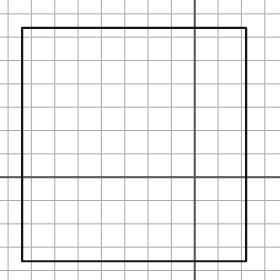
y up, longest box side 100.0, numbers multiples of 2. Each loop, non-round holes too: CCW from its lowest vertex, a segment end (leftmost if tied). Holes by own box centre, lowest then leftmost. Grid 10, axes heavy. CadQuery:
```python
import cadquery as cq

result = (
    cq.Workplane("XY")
    .moveTo(-74.0, -36.0)
    .lineTo(22.0, -36.0)
    .lineTo(22.0, 64.0)
    .lineTo(-74.0, 64.0)
    .close()
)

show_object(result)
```